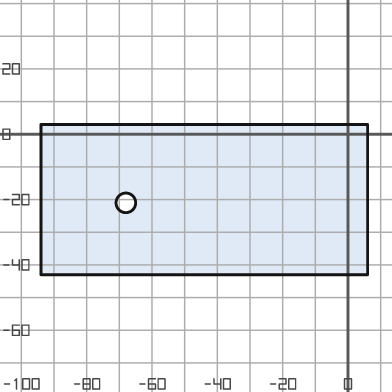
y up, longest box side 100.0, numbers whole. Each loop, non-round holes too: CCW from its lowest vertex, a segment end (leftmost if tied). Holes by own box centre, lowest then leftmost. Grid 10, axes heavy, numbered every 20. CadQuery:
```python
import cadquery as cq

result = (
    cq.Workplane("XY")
    .moveTo(-94.0, -43.0)
    .lineTo(6.0, -43.0)
    .lineTo(6.0, 3.0)
    .lineTo(-94.0, 3.0)
    .close()
    .moveTo(-68.0, -21.0)
    .circle(3.0)
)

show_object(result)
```